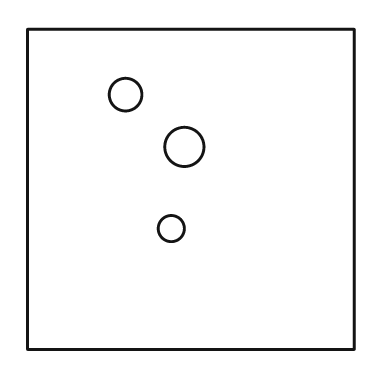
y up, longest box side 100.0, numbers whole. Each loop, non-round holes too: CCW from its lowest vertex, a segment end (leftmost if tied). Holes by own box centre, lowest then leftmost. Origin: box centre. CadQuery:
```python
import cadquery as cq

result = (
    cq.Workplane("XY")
    .moveTo(-50.0, -49.0)
    .lineTo(50.0, -49.0)
    .lineTo(50.0, 49.0)
    .lineTo(-50.0, 49.0)
    .close()
    .moveTo(-6.0, -12.0)
    .circle(4.0)
    .moveTo(-2.0, 13.0)
    .circle(6.0)
    .moveTo(-20.0, 29.0)
    .circle(5.0)
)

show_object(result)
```